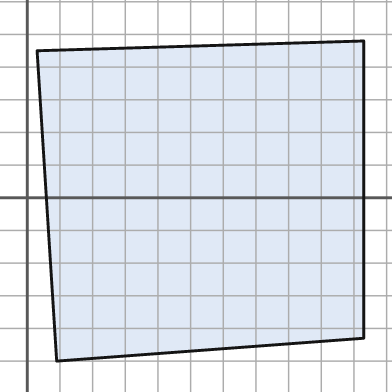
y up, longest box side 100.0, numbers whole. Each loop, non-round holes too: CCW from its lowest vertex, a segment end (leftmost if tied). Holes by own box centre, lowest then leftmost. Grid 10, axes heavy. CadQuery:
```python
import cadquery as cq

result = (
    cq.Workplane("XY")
    .moveTo(9.0, -50.0)
    .lineTo(103.0, -43.0)
    .lineTo(103.0, 48.0)
    .lineTo(3.0, 45.0)
    .close()
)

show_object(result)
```